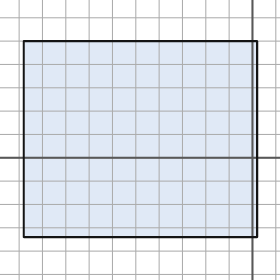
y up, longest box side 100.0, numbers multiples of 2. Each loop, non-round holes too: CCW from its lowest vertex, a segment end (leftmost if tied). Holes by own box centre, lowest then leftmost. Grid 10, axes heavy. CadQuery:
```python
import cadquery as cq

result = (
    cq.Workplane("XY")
    .moveTo(-98.0, -34.0)
    .lineTo(2.0, -34.0)
    .lineTo(2.0, 50.0)
    .lineTo(-98.0, 50.0)
    .close()
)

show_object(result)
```